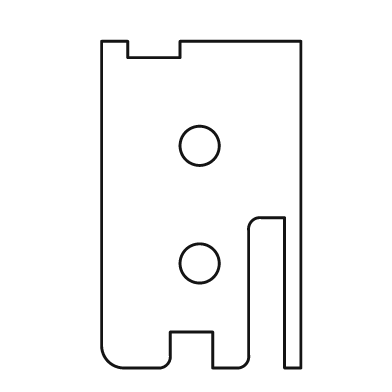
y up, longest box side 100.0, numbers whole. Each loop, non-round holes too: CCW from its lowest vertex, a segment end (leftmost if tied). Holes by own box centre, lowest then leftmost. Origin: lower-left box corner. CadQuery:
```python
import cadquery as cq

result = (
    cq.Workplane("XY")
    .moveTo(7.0, 0.0)
    .lineTo(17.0, 0.0)
    .threePointArc((20.0, 1.0), (21.0, 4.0))
    .lineTo(21.0, 11.0)
    .lineTo(34.0, 11.0)
    .lineTo(34.0, 0.0)
    .lineTo(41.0, 0.0)
    .threePointArc((44.0, 1.0), (45.0, 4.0))
    .lineTo(45.0, 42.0)
    .threePointArc((46.0, 45.0), (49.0, 46.0))
    .lineTo(56.0, 46.0)
    .lineTo(56.0, 0.0)
    .lineTo(61.0, 0.0)
    .lineTo(61.0, 100.0)
    .lineTo(24.0, 100.0)
    .lineTo(24.0, 95.0)
    .lineTo(8.0, 95.0)
    .lineTo(8.0, 100.0)
    .lineTo(0.0, 100.0)
    .lineTo(0.0, 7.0)
    .threePointArc((2.0, 2.0), (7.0, 0.0))
    .close()
    .moveTo(30.0, 32.0)
    .circle(6.0)
    .moveTo(30.0, 68.0)
    .circle(6.0)
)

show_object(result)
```